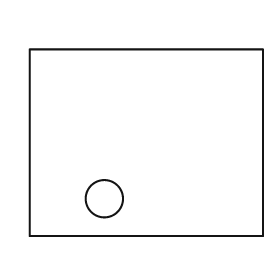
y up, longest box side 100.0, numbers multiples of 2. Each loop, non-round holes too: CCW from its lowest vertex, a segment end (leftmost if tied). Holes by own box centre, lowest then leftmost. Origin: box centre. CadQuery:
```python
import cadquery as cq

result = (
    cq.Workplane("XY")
    .moveTo(-50.0, -40.0)
    .lineTo(50.0, -40.0)
    .lineTo(50.0, 40.0)
    .lineTo(-50.0, 40.0)
    .close()
    .moveTo(-18.0, -24.0)
    .circle(8.0)
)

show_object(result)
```